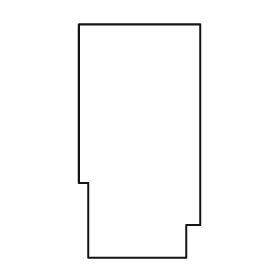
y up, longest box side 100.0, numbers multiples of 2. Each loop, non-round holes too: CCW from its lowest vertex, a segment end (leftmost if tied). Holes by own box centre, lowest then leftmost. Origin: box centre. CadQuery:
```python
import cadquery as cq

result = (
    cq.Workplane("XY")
    .moveTo(-22.0, -50.0)
    .lineTo(20.0, -50.0)
    .lineTo(20.0, -36.0)
    .lineTo(26.0, -36.0)
    .lineTo(26.0, 50.0)
    .lineTo(-26.0, 50.0)
    .lineTo(-26.0, -18.0)
    .lineTo(-22.0, -18.0)
    .close()
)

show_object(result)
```